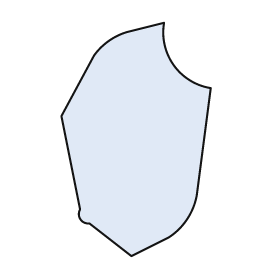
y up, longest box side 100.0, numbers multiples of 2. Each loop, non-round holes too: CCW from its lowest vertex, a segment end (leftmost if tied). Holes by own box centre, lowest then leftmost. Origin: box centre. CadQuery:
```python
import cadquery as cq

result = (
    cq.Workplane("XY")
    .moveTo(-2.0, -50.0)
    .lineTo(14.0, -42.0)
    .threePointArc((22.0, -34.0), (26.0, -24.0))
    .lineTo(32.0, 22.0)
    .threePointArc((16.0, 32.0), (12.0, 50.0))
    .lineTo(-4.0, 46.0)
    .threePointArc((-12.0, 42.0), (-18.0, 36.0))
    .lineTo(-32.0, 10.0)
    .lineTo(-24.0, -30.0)
    .threePointArc((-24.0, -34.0), (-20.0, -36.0))
    .close()
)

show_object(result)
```